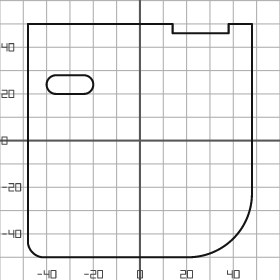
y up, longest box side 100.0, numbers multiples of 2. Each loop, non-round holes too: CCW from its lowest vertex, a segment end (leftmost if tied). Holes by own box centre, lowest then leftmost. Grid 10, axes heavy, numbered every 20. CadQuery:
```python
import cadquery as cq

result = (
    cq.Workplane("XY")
    .moveTo(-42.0, -50.0)
    .lineTo(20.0, -50.0)
    .threePointArc((40.0, -42.0), (48.0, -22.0))
    .lineTo(48.0, 50.0)
    .lineTo(38.0, 50.0)
    .lineTo(38.0, 46.0)
    .lineTo(14.0, 46.0)
    .lineTo(14.0, 50.0)
    .lineTo(-48.0, 50.0)
    .lineTo(-48.0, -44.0)
    .threePointArc((-46.0, -48.0), (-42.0, -50.0))
    .close()
    .moveTo(-36.0, 20.0)
    .lineTo(-24.0, 20.0)
    .threePointArc((-20.0, 24.0), (-24.0, 28.0))
    .lineTo(-36.0, 28.0)
    .threePointArc((-40.0, 24.0), (-36.0, 20.0))
    .close()
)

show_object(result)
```